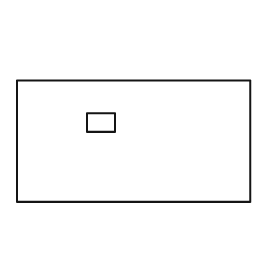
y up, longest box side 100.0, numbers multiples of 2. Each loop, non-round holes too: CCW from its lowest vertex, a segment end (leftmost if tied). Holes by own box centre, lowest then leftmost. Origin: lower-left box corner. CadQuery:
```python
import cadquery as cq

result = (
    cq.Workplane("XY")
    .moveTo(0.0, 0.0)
    .lineTo(100.0, 0.0)
    .lineTo(100.0, 52.0)
    .lineTo(0.0, 52.0)
    .close()
    .moveTo(30.0, 30.0)
    .lineTo(42.0, 30.0)
    .lineTo(42.0, 38.0)
    .lineTo(30.0, 38.0)
    .close()
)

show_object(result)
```